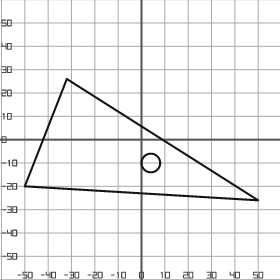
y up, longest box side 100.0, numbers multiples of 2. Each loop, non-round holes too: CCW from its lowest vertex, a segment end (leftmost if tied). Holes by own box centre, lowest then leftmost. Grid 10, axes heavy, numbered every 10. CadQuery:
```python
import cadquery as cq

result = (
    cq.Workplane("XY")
    .moveTo(50.0, -26.0)
    .lineTo(-32.0, 26.0)
    .lineTo(-50.0, -20.0)
    .close()
    .moveTo(4.0, -10.0)
    .circle(4.0)
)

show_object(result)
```